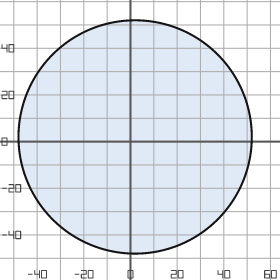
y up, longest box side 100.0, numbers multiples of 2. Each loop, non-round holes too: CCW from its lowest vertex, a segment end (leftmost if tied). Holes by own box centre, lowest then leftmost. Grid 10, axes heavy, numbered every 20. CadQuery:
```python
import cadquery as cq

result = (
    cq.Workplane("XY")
    .moveTo(2.0, 2.0)
    .circle(50.0)
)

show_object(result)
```